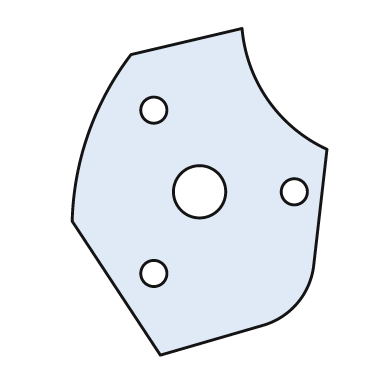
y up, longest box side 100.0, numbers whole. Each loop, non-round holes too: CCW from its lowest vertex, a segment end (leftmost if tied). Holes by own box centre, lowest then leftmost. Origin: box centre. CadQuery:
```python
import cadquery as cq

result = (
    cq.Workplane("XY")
    .moveTo(-12.0, -50.0)
    .lineTo(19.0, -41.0)
    .threePointArc((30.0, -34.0), (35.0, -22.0))
    .lineTo(39.0, 13.0)
    .threePointArc((21.0, 28.0), (13.0, 50.0))
    .lineTo(-21.0, 42.0)
    .threePointArc((-34.0, 18.0), (-39.0, -9.0))
    .close()
    .moveTo(-14.0, -25.0)
    .circle(4.0)
    .moveTo(0.0, 0.0)
    .circle(8.0)
    .moveTo(29.0, 0.0)
    .circle(4.0)
    .moveTo(-14.0, 25.0)
    .circle(4.0)
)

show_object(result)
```